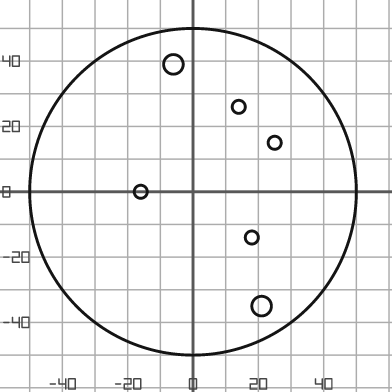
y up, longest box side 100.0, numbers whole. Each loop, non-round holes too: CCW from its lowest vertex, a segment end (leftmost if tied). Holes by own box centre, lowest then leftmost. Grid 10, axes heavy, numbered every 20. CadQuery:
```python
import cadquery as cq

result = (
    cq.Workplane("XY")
    .moveTo(0.0, 0.0)
    .circle(50.0)
    .moveTo(21.0, -35.0)
    .circle(3.0)
    .moveTo(18.0, -14.0)
    .circle(2.0)
    .moveTo(-16.0, 0.0)
    .circle(2.0)
    .moveTo(25.0, 15.0)
    .circle(2.0)
    .moveTo(14.0, 26.0)
    .circle(2.0)
    .moveTo(-6.0, 39.0)
    .circle(3.0)
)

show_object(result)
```